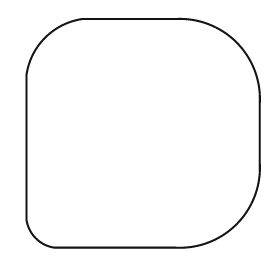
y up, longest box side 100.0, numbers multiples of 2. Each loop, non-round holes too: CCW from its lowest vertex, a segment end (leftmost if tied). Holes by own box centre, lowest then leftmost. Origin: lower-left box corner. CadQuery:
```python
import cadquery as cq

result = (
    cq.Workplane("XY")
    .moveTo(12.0, 0.0)
    .lineTo(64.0, 0.0)
    .threePointArc((90.0, 10.0), (100.0, 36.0))
    .lineTo(100.0, 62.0)
    .threePointArc((90.0, 88.0), (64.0, 98.0))
    .lineTo(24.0, 98.0)
    .threePointArc((8.0, 90.0), (0.0, 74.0))
    .lineTo(0.0, 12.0)
    .threePointArc((4.0, 4.0), (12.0, 0.0))
    .close()
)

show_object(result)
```